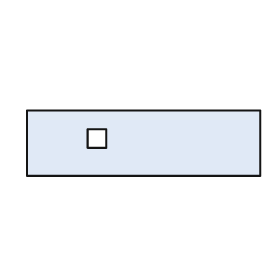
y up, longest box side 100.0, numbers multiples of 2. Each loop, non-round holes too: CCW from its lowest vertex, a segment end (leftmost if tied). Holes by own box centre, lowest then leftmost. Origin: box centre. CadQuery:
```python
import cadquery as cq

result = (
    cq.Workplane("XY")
    .moveTo(-50.0, -14.0)
    .lineTo(50.0, -14.0)
    .lineTo(50.0, 14.0)
    .lineTo(-50.0, 14.0)
    .close()
    .moveTo(-24.0, -2.0)
    .lineTo(-16.0, -2.0)
    .lineTo(-16.0, 6.0)
    .lineTo(-24.0, 6.0)
    .close()
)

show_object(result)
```